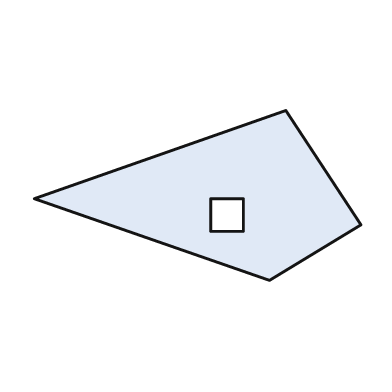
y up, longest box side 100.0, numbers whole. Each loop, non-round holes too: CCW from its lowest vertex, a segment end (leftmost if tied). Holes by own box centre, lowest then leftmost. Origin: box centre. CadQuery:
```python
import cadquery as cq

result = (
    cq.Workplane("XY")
    .moveTo(22.0, -26.0)
    .lineTo(50.0, -9.0)
    .lineTo(27.0, 26.0)
    .lineTo(-50.0, -1.0)
    .close()
    .moveTo(4.0, -11.0)
    .lineTo(14.0, -11.0)
    .lineTo(14.0, -1.0)
    .lineTo(4.0, -1.0)
    .close()
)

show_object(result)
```